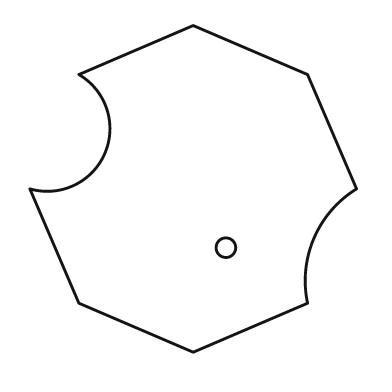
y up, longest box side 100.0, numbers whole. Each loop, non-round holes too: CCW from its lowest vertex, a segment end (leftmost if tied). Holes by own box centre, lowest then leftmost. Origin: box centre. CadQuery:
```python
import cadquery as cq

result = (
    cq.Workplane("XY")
    .moveTo(0.0, -50.0)
    .lineTo(35.0, -35.0)
    .threePointArc((37.0, -15.0), (50.0, 0.0))
    .lineTo(35.0, 35.0)
    .lineTo(0.0, 50.0)
    .lineTo(-35.0, 35.0)
    .threePointArc((-27.0, 11.0), (-50.0, 0.0))
    .lineTo(-35.0, -35.0)
    .close()
    .moveTo(10.0, -18.0)
    .circle(3.0)
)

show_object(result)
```